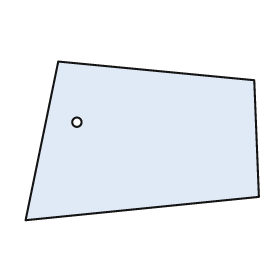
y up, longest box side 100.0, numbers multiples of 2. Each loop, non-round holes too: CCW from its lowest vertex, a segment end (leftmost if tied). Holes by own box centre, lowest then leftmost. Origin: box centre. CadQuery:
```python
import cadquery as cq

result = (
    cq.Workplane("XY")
    .moveTo(-50.0, -34.0)
    .lineTo(50.0, -24.0)
    .lineTo(48.0, 26.0)
    .lineTo(-36.0, 34.0)
    .close()
    .moveTo(-28.0, 8.0)
    .circle(2.0)
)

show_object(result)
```